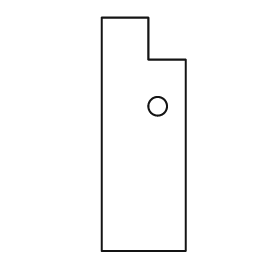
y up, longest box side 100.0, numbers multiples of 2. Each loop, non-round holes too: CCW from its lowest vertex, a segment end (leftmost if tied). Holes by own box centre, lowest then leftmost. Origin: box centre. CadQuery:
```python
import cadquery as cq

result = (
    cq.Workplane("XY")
    .moveTo(-18.0, -50.0)
    .lineTo(18.0, -50.0)
    .lineTo(18.0, 32.0)
    .lineTo(2.0, 32.0)
    .lineTo(2.0, 50.0)
    .lineTo(-18.0, 50.0)
    .close()
    .moveTo(6.0, 12.0)
    .circle(4.0)
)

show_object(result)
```